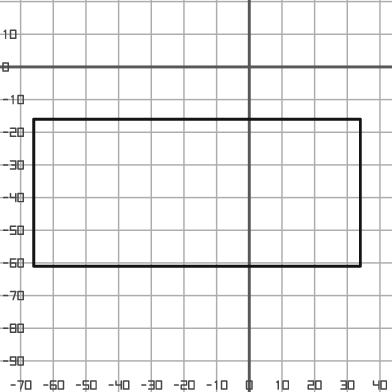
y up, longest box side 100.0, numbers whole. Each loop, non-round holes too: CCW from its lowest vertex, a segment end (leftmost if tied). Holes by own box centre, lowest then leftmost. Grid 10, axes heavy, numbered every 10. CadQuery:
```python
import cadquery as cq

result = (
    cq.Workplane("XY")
    .moveTo(-66.0, -61.0)
    .lineTo(34.0, -61.0)
    .lineTo(34.0, -16.0)
    .lineTo(-66.0, -16.0)
    .close()
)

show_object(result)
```